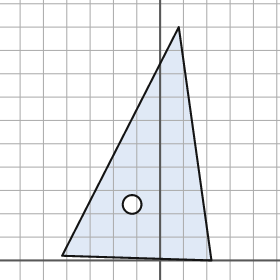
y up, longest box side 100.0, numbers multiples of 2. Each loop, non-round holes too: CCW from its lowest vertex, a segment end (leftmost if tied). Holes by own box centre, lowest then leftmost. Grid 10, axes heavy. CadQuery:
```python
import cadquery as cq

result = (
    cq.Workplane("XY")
    .moveTo(22.0, 0.0)
    .lineTo(8.0, 100.0)
    .lineTo(-42.0, 2.0)
    .close()
    .moveTo(-12.0, 24.0)
    .circle(4.0)
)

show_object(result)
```